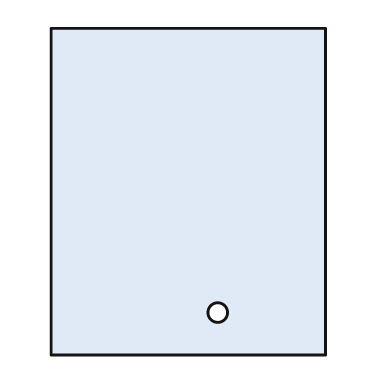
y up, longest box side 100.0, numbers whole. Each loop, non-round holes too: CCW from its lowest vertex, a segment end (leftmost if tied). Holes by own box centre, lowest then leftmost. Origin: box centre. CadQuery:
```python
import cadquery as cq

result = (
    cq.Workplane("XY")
    .moveTo(-42.0, -50.0)
    .lineTo(42.0, -50.0)
    .lineTo(42.0, 50.0)
    .lineTo(-42.0, 50.0)
    .close()
    .moveTo(9.0, -37.0)
    .circle(3.0)
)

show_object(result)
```